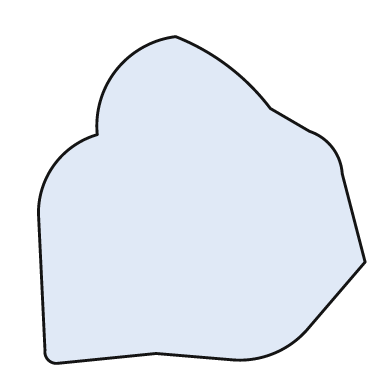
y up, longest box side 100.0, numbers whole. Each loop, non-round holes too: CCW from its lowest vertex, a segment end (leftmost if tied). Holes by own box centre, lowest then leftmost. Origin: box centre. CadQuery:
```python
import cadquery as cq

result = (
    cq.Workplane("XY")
    .moveTo(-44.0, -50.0)
    .lineTo(-14.0, -47.0)
    .lineTo(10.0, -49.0)
    .threePointArc((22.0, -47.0), (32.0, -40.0))
    .lineTo(50.0, -19.0)
    .lineTo(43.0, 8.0)
    .threePointArc((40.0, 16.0), (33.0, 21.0))
    .lineTo(21.0, 28.0)
    .threePointArc((8.0, 41.0), (-8.0, 50.0))
    .threePointArc((-26.0, 40.0), (-32.0, 20.0))
    .threePointArc((-45.0, 11.0), (-50.0, -4.0))
    .lineTo(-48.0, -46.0)
    .threePointArc((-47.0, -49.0), (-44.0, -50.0))
    .close()
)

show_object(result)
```